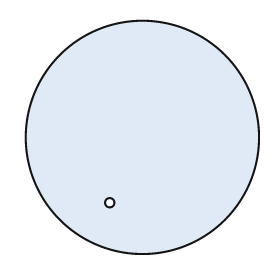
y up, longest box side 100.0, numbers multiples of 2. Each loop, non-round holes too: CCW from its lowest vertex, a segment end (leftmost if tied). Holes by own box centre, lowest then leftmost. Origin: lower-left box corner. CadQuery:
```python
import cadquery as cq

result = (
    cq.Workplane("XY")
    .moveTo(50.0, 50.0)
    .circle(50.0)
    .moveTo(36.0, 22.0)
    .circle(2.0)
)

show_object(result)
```